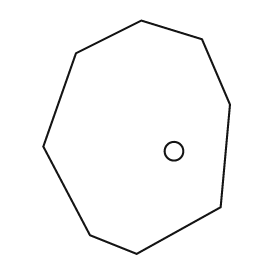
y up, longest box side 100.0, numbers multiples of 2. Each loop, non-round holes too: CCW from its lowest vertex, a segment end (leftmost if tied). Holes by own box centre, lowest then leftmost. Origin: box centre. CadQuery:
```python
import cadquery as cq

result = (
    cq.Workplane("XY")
    .moveTo(0.0, -50.0)
    .lineTo(36.0, -30.0)
    .lineTo(40.0, 14.0)
    .lineTo(28.0, 42.0)
    .lineTo(2.0, 50.0)
    .lineTo(-26.0, 36.0)
    .lineTo(-40.0, -4.0)
    .lineTo(-20.0, -42.0)
    .close()
    .moveTo(16.0, -6.0)
    .circle(4.0)
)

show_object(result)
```